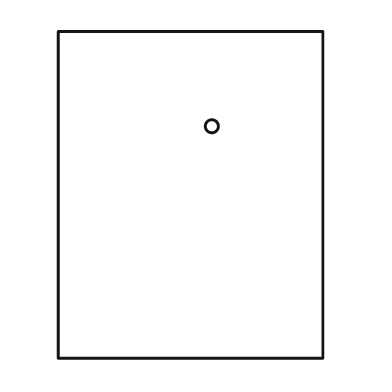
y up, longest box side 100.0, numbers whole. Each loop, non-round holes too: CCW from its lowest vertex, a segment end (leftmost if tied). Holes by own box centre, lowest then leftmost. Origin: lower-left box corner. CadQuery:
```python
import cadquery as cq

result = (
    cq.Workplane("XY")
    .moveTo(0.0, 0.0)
    .lineTo(81.0, 0.0)
    .lineTo(81.0, 100.0)
    .lineTo(0.0, 100.0)
    .close()
    .moveTo(47.0, 71.0)
    .circle(2.0)
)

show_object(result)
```